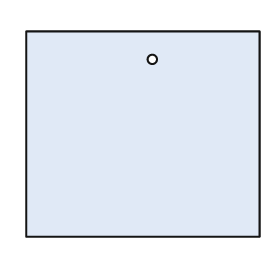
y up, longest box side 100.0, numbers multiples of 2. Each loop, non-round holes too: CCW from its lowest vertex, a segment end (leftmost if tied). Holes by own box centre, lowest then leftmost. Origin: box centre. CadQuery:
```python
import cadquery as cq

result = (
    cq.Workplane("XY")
    .moveTo(-50.0, -44.0)
    .lineTo(50.0, -44.0)
    .lineTo(50.0, 44.0)
    .lineTo(-50.0, 44.0)
    .close()
    .moveTo(4.0, 32.0)
    .circle(2.0)
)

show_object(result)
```